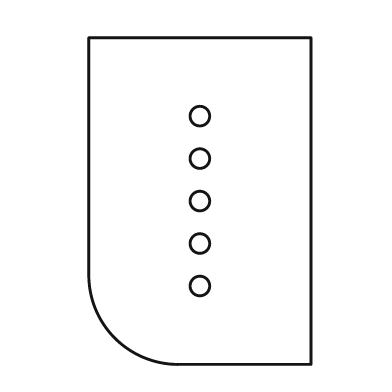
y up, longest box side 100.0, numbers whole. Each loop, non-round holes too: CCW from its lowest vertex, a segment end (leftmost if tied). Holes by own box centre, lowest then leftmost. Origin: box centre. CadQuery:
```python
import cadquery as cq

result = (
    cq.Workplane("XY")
    .moveTo(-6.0, -50.0)
    .lineTo(34.0, -50.0)
    .lineTo(34.0, 50.0)
    .lineTo(-34.0, 50.0)
    .lineTo(-34.0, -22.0)
    .threePointArc((-26.0, -42.0), (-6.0, -50.0))
    .close()
    .moveTo(0.0, -26.0)
    .circle(3.0)
    .moveTo(0.0, -13.0)
    .circle(3.0)
    .moveTo(0.0, 0.0)
    .circle(3.0)
    .moveTo(0.0, 13.0)
    .circle(3.0)
    .moveTo(0.0, 26.0)
    .circle(3.0)
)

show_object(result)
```